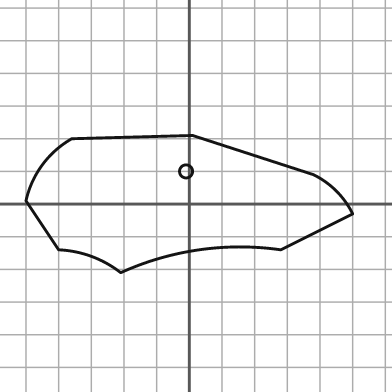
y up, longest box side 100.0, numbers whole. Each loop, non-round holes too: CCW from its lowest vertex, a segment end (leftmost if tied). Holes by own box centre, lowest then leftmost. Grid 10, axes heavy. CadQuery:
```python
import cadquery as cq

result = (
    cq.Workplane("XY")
    .moveTo(-21.0, -21.0)
    .threePointArc((3.0, -14.0), (28.0, -14.0))
    .lineTo(50.0, -3.0)
    .threePointArc((45.0, 4.0), (38.0, 9.0))
    .lineTo(1.0, 21.0)
    .lineTo(-36.0, 20.0)
    .threePointArc((-45.0, 12.0), (-50.0, 1.0))
    .lineTo(-40.0, -14.0)
    .threePointArc((-30.0, -16.0), (-21.0, -21.0))
    .close()
    .moveTo(-1.0, 10.0)
    .circle(2.0)
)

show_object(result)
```